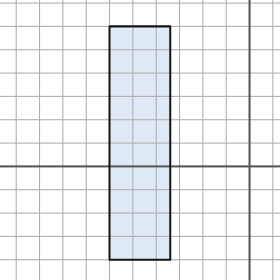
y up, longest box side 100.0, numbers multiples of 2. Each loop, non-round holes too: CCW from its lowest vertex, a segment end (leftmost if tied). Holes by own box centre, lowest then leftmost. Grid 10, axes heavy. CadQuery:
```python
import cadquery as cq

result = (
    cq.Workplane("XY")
    .moveTo(-60.0, -40.0)
    .lineTo(-34.0, -40.0)
    .lineTo(-34.0, 60.0)
    .lineTo(-60.0, 60.0)
    .close()
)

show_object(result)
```